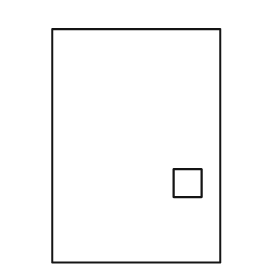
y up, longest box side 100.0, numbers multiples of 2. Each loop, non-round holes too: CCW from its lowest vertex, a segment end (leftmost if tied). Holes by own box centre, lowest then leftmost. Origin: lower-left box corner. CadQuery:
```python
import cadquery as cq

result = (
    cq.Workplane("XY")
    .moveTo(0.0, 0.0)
    .lineTo(72.0, 0.0)
    .lineTo(72.0, 100.0)
    .lineTo(0.0, 100.0)
    .close()
    .moveTo(52.0, 28.0)
    .lineTo(64.0, 28.0)
    .lineTo(64.0, 40.0)
    .lineTo(52.0, 40.0)
    .close()
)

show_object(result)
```